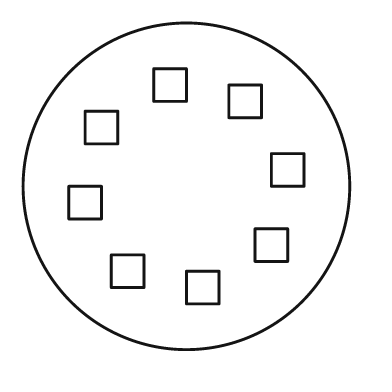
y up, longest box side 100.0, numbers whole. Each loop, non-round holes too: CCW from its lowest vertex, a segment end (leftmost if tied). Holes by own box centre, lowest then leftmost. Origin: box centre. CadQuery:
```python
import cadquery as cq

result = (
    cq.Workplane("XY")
    .moveTo(0.0, 0.0)
    .circle(50.0)
    .moveTo(0.0, -36.0)
    .lineTo(10.0, -36.0)
    .lineTo(10.0, -26.0)
    .lineTo(0.0, -26.0)
    .close()
    .moveTo(-23.0, -31.0)
    .lineTo(-13.0, -31.0)
    .lineTo(-13.0, -21.0)
    .lineTo(-23.0, -21.0)
    .close()
    .moveTo(21.0, -23.0)
    .lineTo(31.0, -23.0)
    .lineTo(31.0, -13.0)
    .lineTo(21.0, -13.0)
    .close()
    .moveTo(-36.0, -10.0)
    .lineTo(-26.0, -10.0)
    .lineTo(-26.0, 0.0)
    .lineTo(-36.0, 0.0)
    .close()
    .moveTo(26.0, 0.0)
    .lineTo(36.0, 0.0)
    .lineTo(36.0, 10.0)
    .lineTo(26.0, 10.0)
    .close()
    .moveTo(-31.0, 13.0)
    .lineTo(-21.0, 13.0)
    .lineTo(-21.0, 23.0)
    .lineTo(-31.0, 23.0)
    .close()
    .moveTo(13.0, 21.0)
    .lineTo(23.0, 21.0)
    .lineTo(23.0, 31.0)
    .lineTo(13.0, 31.0)
    .close()
    .moveTo(-10.0, 26.0)
    .lineTo(0.0, 26.0)
    .lineTo(0.0, 36.0)
    .lineTo(-10.0, 36.0)
    .close()
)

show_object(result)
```